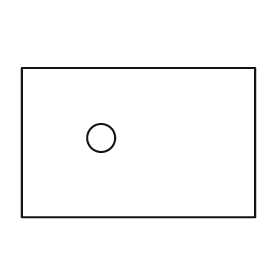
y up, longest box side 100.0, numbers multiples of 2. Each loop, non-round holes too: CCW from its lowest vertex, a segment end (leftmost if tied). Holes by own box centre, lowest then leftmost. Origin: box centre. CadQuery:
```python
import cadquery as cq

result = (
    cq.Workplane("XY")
    .moveTo(-50.0, -32.0)
    .lineTo(50.0, -32.0)
    .lineTo(50.0, 32.0)
    .lineTo(-50.0, 32.0)
    .close()
    .moveTo(-16.0, 2.0)
    .circle(6.0)
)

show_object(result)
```